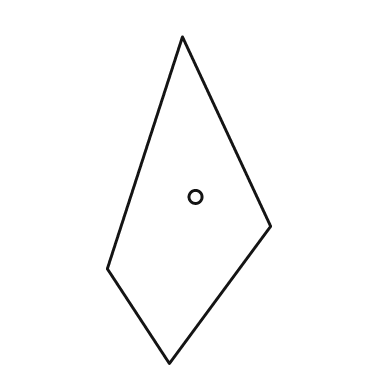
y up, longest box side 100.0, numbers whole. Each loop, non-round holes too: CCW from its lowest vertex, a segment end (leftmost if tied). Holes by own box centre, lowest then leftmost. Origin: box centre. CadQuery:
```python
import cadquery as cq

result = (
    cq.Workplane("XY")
    .moveTo(-6.0, -50.0)
    .lineTo(25.0, -8.0)
    .lineTo(-2.0, 50.0)
    .lineTo(-25.0, -21.0)
    .close()
    .moveTo(2.0, 1.0)
    .circle(2.0)
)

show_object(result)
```